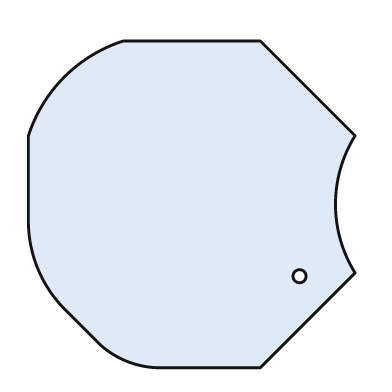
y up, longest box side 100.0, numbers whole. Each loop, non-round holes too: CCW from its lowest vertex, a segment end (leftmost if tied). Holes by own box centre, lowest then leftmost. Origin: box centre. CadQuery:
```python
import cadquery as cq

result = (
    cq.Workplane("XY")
    .moveTo(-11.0, -50.0)
    .lineTo(21.0, -50.0)
    .lineTo(50.0, -21.0)
    .threePointArc((44.0, 0.0), (50.0, 21.0))
    .lineTo(21.0, 50.0)
    .lineTo(-21.0, 50.0)
    .threePointArc((-39.0, 39.0), (-50.0, 21.0))
    .lineTo(-50.0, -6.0)
    .threePointArc((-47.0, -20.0), (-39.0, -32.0))
    .lineTo(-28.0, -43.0)
    .threePointArc((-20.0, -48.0), (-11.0, -50.0))
    .close()
    .moveTo(33.0, -22.0)
    .circle(2.0)
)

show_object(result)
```